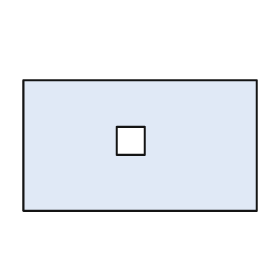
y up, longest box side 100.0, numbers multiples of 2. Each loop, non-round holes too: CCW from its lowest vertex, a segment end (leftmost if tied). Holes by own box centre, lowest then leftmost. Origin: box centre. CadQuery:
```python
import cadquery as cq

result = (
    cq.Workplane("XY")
    .moveTo(-50.0, -28.0)
    .lineTo(50.0, -28.0)
    .lineTo(50.0, 28.0)
    .lineTo(-50.0, 28.0)
    .close()
    .moveTo(-10.0, -4.0)
    .lineTo(2.0, -4.0)
    .lineTo(2.0, 8.0)
    .lineTo(-10.0, 8.0)
    .close()
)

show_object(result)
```